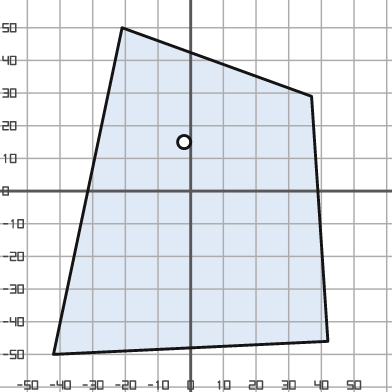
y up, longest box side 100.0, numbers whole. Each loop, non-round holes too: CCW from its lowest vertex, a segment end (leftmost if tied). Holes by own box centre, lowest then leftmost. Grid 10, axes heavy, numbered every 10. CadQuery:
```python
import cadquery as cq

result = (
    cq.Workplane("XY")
    .moveTo(-42.0, -50.0)
    .lineTo(42.0, -46.0)
    .lineTo(37.0, 29.0)
    .lineTo(-21.0, 50.0)
    .close()
    .moveTo(-2.0, 15.0)
    .circle(2.0)
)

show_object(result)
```